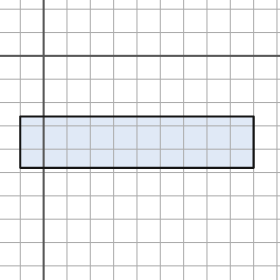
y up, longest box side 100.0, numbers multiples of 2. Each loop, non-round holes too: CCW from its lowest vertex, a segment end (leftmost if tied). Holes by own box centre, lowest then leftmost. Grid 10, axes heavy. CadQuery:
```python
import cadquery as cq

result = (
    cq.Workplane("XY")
    .moveTo(-10.0, -48.0)
    .lineTo(90.0, -48.0)
    .lineTo(90.0, -26.0)
    .lineTo(-10.0, -26.0)
    .close()
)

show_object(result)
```